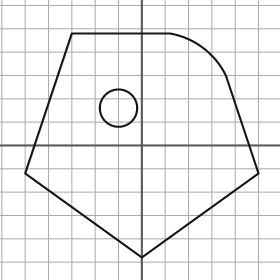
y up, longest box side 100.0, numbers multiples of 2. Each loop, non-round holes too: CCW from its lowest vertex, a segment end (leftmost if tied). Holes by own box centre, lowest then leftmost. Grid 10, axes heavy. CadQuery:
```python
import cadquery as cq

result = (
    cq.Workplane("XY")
    .moveTo(0.0, -48.0)
    .lineTo(50.0, -12.0)
    .lineTo(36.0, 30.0)
    .threePointArc((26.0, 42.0), (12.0, 48.0))
    .lineTo(-30.0, 48.0)
    .lineTo(-50.0, -12.0)
    .close()
    .moveTo(-10.0, 16.0)
    .circle(8.0)
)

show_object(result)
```